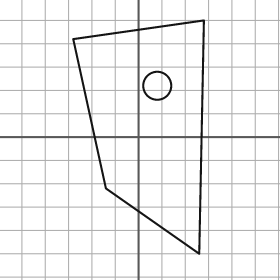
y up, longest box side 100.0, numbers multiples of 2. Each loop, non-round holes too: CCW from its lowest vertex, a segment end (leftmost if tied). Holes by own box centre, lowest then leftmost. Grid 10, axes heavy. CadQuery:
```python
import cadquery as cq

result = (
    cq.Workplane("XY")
    .moveTo(26.0, -50.0)
    .lineTo(28.0, 50.0)
    .lineTo(-28.0, 42.0)
    .lineTo(-14.0, -22.0)
    .close()
    .moveTo(8.0, 22.0)
    .circle(6.0)
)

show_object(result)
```